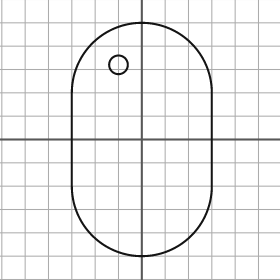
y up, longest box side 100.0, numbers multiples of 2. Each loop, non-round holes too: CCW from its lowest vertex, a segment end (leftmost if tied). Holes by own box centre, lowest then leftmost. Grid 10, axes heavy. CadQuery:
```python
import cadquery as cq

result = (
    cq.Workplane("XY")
    .moveTo(-30.0, -20.0)
    .threePointArc((0.0, -50.0), (30.0, -20.0))
    .lineTo(30.0, 20.0)
    .threePointArc((0.0, 50.0), (-30.0, 20.0))
    .close()
    .moveTo(-10.0, 32.0)
    .circle(4.0)
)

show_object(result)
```